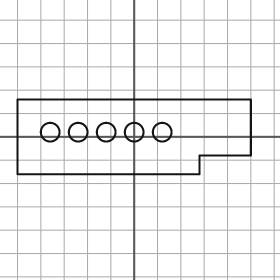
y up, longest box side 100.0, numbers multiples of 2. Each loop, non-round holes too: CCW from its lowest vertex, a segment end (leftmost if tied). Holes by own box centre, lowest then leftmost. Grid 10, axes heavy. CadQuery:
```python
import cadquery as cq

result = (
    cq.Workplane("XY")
    .moveTo(-50.0, -16.0)
    .lineTo(28.0, -16.0)
    .lineTo(28.0, -8.0)
    .lineTo(50.0, -8.0)
    .lineTo(50.0, 16.0)
    .lineTo(-50.0, 16.0)
    .close()
    .moveTo(-36.0, 2.0)
    .circle(4.0)
    .moveTo(-24.0, 2.0)
    .circle(4.0)
    .moveTo(-12.0, 2.0)
    .circle(4.0)
    .moveTo(0.0, 2.0)
    .circle(4.0)
    .moveTo(12.0, 2.0)
    .circle(4.0)
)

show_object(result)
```